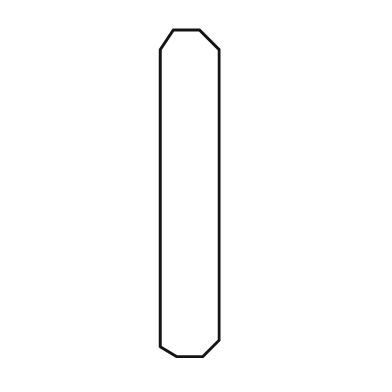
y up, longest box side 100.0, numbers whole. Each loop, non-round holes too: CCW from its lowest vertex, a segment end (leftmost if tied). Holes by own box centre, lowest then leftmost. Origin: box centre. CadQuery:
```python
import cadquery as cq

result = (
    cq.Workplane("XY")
    .moveTo(-4.0, -50.0)
    .lineTo(4.0, -50.0)
    .lineTo(9.0, -45.0)
    .lineTo(9.0, 44.0)
    .lineTo(3.0, 50.0)
    .lineTo(-5.0, 50.0)
    .lineTo(-9.0, 44.0)
    .lineTo(-9.0, -47.0)
    .close()
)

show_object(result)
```